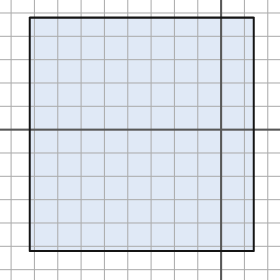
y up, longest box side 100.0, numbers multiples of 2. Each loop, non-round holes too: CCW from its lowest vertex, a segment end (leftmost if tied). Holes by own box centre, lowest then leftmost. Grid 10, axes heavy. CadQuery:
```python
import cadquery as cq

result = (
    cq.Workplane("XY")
    .moveTo(-82.0, -52.0)
    .lineTo(14.0, -52.0)
    .lineTo(14.0, 48.0)
    .lineTo(-82.0, 48.0)
    .close()
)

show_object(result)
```